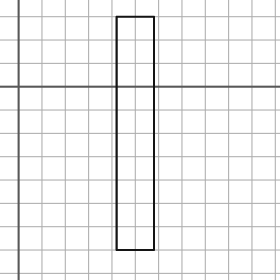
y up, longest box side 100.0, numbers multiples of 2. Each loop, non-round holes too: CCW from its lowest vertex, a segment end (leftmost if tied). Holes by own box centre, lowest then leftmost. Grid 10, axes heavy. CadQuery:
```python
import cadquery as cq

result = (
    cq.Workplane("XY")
    .moveTo(42.0, -70.0)
    .lineTo(58.0, -70.0)
    .lineTo(58.0, 30.0)
    .lineTo(42.0, 30.0)
    .close()
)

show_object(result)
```